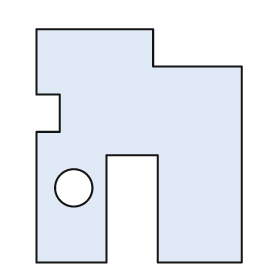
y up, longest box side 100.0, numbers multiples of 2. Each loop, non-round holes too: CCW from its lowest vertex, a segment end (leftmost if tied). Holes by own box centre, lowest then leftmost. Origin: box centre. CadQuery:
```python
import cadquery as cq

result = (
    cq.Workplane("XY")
    .moveTo(-44.0, -50.0)
    .lineTo(-14.0, -50.0)
    .lineTo(-14.0, -4.0)
    .lineTo(8.0, -4.0)
    .lineTo(8.0, -50.0)
    .lineTo(44.0, -50.0)
    .lineTo(44.0, 34.0)
    .lineTo(6.0, 34.0)
    .lineTo(6.0, 50.0)
    .lineTo(-44.0, 50.0)
    .lineTo(-44.0, 22.0)
    .lineTo(-34.0, 22.0)
    .lineTo(-34.0, 6.0)
    .lineTo(-44.0, 6.0)
    .close()
    .moveTo(-28.0, -18.0)
    .circle(8.0)
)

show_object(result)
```